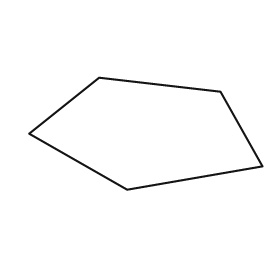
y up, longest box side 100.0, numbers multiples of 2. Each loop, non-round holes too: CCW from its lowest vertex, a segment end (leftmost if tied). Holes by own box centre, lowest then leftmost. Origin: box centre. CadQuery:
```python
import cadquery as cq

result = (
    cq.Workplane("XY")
    .moveTo(-8.0, -24.0)
    .lineTo(50.0, -14.0)
    .lineTo(32.0, 18.0)
    .lineTo(-20.0, 24.0)
    .lineTo(-50.0, 0.0)
    .close()
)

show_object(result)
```